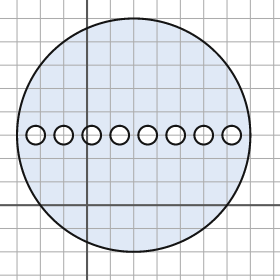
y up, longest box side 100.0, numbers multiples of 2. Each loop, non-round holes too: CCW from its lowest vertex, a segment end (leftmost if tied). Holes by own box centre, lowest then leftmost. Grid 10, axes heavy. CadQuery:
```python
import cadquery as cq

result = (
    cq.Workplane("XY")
    .moveTo(20.0, 30.0)
    .circle(50.0)
    .moveTo(-22.0, 30.0)
    .circle(4.0)
    .moveTo(-10.0, 30.0)
    .circle(4.0)
    .moveTo(2.0, 30.0)
    .circle(4.0)
    .moveTo(14.0, 30.0)
    .circle(4.0)
    .moveTo(26.0, 30.0)
    .circle(4.0)
    .moveTo(38.0, 30.0)
    .circle(4.0)
    .moveTo(50.0, 30.0)
    .circle(4.0)
    .moveTo(62.0, 30.0)
    .circle(4.0)
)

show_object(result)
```